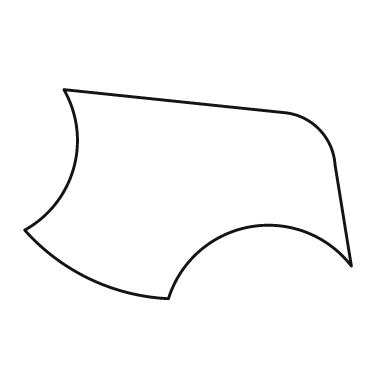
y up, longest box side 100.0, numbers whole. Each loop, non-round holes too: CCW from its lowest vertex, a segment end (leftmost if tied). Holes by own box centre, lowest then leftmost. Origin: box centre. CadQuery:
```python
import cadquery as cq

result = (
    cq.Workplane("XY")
    .moveTo(-6.0, -32.0)
    .threePointArc((19.0, -10.0), (50.0, -22.0))
    .lineTo(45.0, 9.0)
    .threePointArc((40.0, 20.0), (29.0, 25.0))
    .lineTo(-38.0, 32.0)
    .threePointArc((-35.0, 8.0), (-50.0, -11.0))
    .threePointArc((-30.0, -26.0), (-6.0, -32.0))
    .close()
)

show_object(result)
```